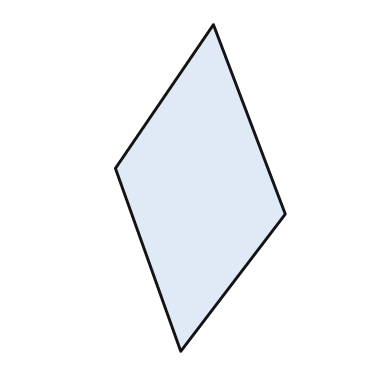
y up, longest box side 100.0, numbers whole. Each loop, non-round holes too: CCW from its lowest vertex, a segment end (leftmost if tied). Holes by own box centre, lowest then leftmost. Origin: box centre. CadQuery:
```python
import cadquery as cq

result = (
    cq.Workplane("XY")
    .moveTo(-6.0, -50.0)
    .lineTo(26.0, -8.0)
    .lineTo(4.0, 50.0)
    .lineTo(-26.0, 6.0)
    .close()
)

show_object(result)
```